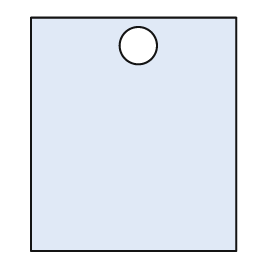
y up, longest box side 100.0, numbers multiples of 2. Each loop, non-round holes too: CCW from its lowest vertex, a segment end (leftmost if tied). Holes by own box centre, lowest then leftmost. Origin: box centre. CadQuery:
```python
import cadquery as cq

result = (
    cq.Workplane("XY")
    .moveTo(-44.0, -50.0)
    .lineTo(44.0, -50.0)
    .lineTo(44.0, 50.0)
    .lineTo(-44.0, 50.0)
    .close()
    .moveTo(2.0, 38.0)
    .circle(8.0)
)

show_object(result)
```